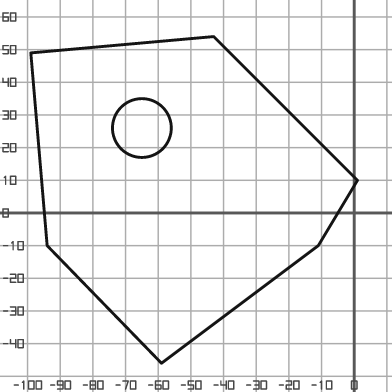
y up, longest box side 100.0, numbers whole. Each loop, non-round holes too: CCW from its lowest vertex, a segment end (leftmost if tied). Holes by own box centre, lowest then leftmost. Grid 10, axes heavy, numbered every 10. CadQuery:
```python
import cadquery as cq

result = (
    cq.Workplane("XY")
    .moveTo(-59.0, -46.0)
    .lineTo(-11.0, -10.0)
    .lineTo(1.0, 10.0)
    .lineTo(-43.0, 54.0)
    .lineTo(-99.0, 49.0)
    .lineTo(-94.0, -10.0)
    .close()
    .moveTo(-65.0, 26.0)
    .circle(9.0)
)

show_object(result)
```